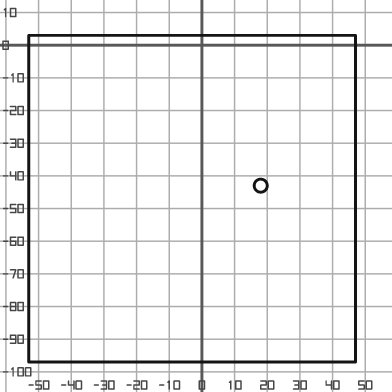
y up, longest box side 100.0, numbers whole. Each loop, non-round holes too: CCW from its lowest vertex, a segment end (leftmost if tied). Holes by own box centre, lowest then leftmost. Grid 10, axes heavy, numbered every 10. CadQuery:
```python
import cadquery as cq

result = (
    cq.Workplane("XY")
    .moveTo(-53.0, -97.0)
    .lineTo(47.0, -97.0)
    .lineTo(47.0, 3.0)
    .lineTo(-53.0, 3.0)
    .close()
    .moveTo(18.0, -43.0)
    .circle(2.0)
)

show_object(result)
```